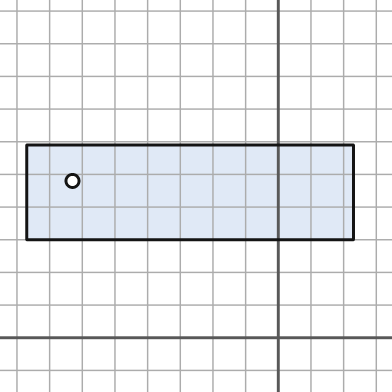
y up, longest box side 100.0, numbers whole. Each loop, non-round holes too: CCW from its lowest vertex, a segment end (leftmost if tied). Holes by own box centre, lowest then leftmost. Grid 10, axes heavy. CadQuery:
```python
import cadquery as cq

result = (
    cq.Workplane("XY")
    .moveTo(-77.0, 30.0)
    .lineTo(23.0, 30.0)
    .lineTo(23.0, 59.0)
    .lineTo(-77.0, 59.0)
    .close()
    .moveTo(-63.0, 48.0)
    .circle(2.0)
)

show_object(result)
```